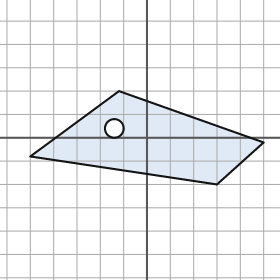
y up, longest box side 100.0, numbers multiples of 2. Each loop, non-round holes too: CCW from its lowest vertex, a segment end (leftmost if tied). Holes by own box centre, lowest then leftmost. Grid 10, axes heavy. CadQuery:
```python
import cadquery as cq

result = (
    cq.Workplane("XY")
    .moveTo(30.0, -20.0)
    .lineTo(50.0, -2.0)
    .lineTo(-12.0, 20.0)
    .lineTo(-50.0, -8.0)
    .close()
    .moveTo(-14.0, 4.0)
    .circle(4.0)
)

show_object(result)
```